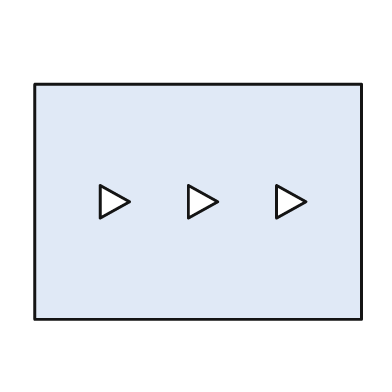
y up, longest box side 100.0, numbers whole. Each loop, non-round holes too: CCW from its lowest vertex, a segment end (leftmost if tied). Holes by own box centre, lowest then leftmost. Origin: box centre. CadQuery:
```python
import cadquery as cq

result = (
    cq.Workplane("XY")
    .moveTo(-50.0, -36.0)
    .lineTo(50.0, -36.0)
    .lineTo(50.0, 36.0)
    .lineTo(-50.0, 36.0)
    .close()
    .moveTo(-30.0, -5.0)
    .lineTo(-21.0, 0.0)
    .lineTo(-30.0, 5.0)
    .close()
    .moveTo(-3.0, -5.0)
    .lineTo(6.0, 0.0)
    .lineTo(-3.0, 5.0)
    .close()
    .moveTo(24.0, -5.0)
    .lineTo(33.0, 0.0)
    .lineTo(24.0, 5.0)
    .close()
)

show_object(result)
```